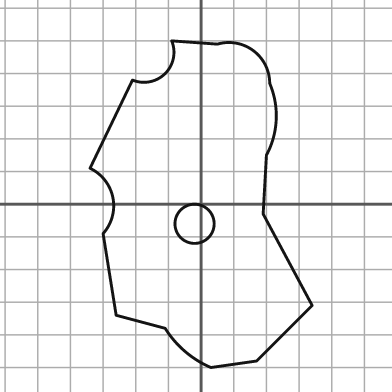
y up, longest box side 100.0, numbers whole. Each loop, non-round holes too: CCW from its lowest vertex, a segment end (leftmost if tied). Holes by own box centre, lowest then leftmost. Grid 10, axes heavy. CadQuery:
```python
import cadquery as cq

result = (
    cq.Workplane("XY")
    .moveTo(3.0, -50.0)
    .lineTo(17.0, -48.0)
    .lineTo(34.0, -31.0)
    .lineTo(19.0, -3.0)
    .lineTo(20.0, 15.0)
    .threePointArc((23.0, 26.0), (21.0, 37.0))
    .threePointArc((16.0, 47.0), (5.0, 49.0))
    .lineTo(-9.0, 50.0)
    .threePointArc((-11.0, 40.0), (-21.0, 38.0))
    .lineTo(-34.0, 11.0)
    .threePointArc((-27.0, 2.0), (-30.0, -9.0))
    .lineTo(-26.0, -34.0)
    .lineTo(-11.0, -38.0)
    .threePointArc((-5.0, -45.0), (3.0, -50.0))
    .close()
    .moveTo(-2.0, -6.0)
    .circle(6.0)
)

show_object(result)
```